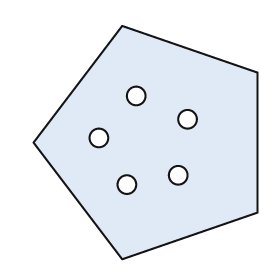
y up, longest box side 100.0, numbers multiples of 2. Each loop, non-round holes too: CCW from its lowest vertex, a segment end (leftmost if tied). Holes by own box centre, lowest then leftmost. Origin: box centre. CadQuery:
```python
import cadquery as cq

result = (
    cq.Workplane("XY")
    .moveTo(-10.0, -50.0)
    .lineTo(48.0, -30.0)
    .lineTo(48.0, 30.0)
    .lineTo(-10.0, 50.0)
    .lineTo(-48.0, 0.0)
    .close()
    .moveTo(-8.0, -18.0)
    .circle(4.0)
    .moveTo(14.0, -14.0)
    .circle(4.0)
    .moveTo(-20.0, 2.0)
    .circle(4.0)
    .moveTo(18.0, 10.0)
    .circle(4.0)
    .moveTo(-4.0, 20.0)
    .circle(4.0)
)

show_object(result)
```